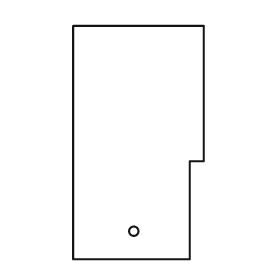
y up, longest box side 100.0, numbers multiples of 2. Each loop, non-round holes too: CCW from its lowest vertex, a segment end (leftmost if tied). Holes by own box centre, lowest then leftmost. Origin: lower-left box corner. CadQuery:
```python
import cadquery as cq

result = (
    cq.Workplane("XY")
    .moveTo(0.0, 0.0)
    .lineTo(50.0, 0.0)
    .lineTo(50.0, 42.0)
    .lineTo(56.0, 42.0)
    .lineTo(56.0, 100.0)
    .lineTo(0.0, 100.0)
    .close()
    .moveTo(26.0, 12.0)
    .circle(2.0)
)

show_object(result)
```